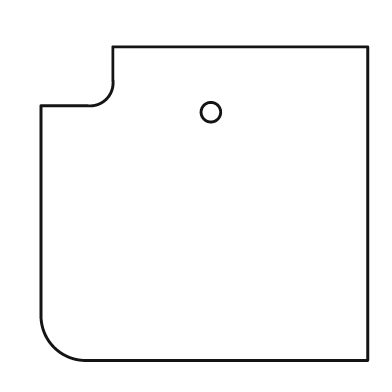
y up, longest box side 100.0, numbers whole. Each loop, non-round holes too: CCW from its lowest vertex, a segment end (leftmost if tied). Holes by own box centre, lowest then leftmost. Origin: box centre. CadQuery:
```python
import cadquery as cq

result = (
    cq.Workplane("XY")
    .moveTo(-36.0, -48.0)
    .lineTo(50.0, -48.0)
    .lineTo(50.0, 48.0)
    .lineTo(-28.0, 48.0)
    .lineTo(-28.0, 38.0)
    .threePointArc((-30.0, 32.0), (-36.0, 30.0))
    .lineTo(-50.0, 30.0)
    .lineTo(-50.0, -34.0)
    .threePointArc((-46.0, -44.0), (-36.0, -48.0))
    .close()
    .moveTo(2.0, 28.0)
    .circle(3.0)
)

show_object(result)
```